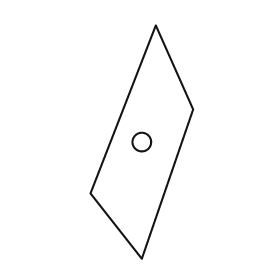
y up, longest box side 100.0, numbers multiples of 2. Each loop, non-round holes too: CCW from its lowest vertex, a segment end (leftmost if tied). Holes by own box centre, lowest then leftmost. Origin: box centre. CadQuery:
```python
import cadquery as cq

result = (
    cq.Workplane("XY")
    .moveTo(0.0, -50.0)
    .lineTo(22.0, 14.0)
    .lineTo(6.0, 50.0)
    .lineTo(-22.0, -22.0)
    .close()
    .moveTo(0.0, 0.0)
    .circle(4.0)
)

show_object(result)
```